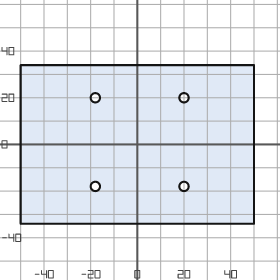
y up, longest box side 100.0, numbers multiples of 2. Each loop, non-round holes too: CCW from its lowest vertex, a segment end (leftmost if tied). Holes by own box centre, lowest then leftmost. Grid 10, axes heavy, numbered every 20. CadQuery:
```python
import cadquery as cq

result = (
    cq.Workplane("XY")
    .moveTo(-50.0, -34.0)
    .lineTo(50.0, -34.0)
    .lineTo(50.0, 34.0)
    .lineTo(-50.0, 34.0)
    .close()
    .moveTo(-18.0, -18.0)
    .circle(2.0)
    .moveTo(20.0, -18.0)
    .circle(2.0)
    .moveTo(-18.0, 20.0)
    .circle(2.0)
    .moveTo(20.0, 20.0)
    .circle(2.0)
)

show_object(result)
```